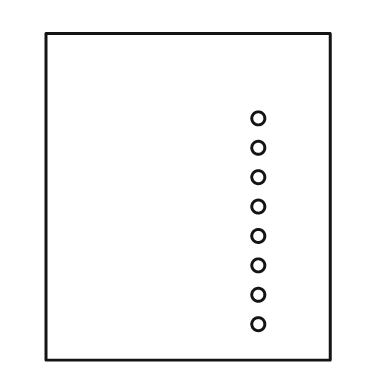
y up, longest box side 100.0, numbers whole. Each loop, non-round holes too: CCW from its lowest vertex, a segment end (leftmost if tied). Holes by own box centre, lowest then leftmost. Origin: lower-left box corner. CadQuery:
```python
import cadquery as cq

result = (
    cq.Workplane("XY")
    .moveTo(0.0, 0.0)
    .lineTo(87.0, 0.0)
    .lineTo(87.0, 100.0)
    .lineTo(0.0, 100.0)
    .close()
    .moveTo(65.0, 11.0)
    .circle(2.0)
    .moveTo(65.0, 20.0)
    .circle(2.0)
    .moveTo(65.0, 29.0)
    .circle(2.0)
    .moveTo(65.0, 38.0)
    .circle(2.0)
    .moveTo(65.0, 47.0)
    .circle(2.0)
    .moveTo(65.0, 56.0)
    .circle(2.0)
    .moveTo(65.0, 65.0)
    .circle(2.0)
    .moveTo(65.0, 74.0)
    .circle(2.0)
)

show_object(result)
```